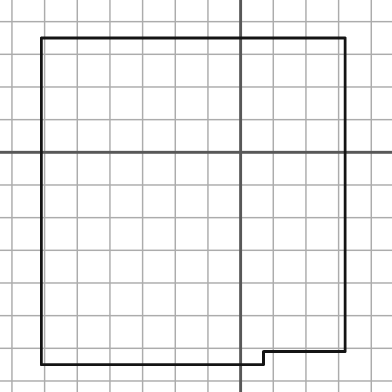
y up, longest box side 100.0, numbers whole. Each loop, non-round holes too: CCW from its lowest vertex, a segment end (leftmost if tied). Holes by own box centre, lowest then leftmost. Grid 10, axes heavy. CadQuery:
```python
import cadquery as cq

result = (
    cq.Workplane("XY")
    .moveTo(-61.0, -65.0)
    .lineTo(7.0, -65.0)
    .lineTo(7.0, -61.0)
    .lineTo(32.0, -61.0)
    .lineTo(32.0, 35.0)
    .lineTo(-61.0, 35.0)
    .close()
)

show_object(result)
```